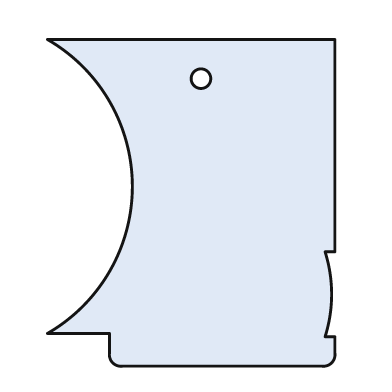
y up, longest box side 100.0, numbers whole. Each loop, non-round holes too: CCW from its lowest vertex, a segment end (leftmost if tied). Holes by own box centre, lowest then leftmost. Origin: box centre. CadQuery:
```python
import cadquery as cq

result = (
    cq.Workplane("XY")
    .moveTo(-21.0, -50.0)
    .lineTo(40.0, -50.0)
    .threePointArc((43.0, -49.0), (44.0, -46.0))
    .lineTo(44.0, -41.0)
    .lineTo(41.0, -41.0)
    .threePointArc((43.0, -28.0), (41.0, -15.0))
    .lineTo(44.0, -15.0)
    .lineTo(44.0, 50.0)
    .lineTo(-44.0, 50.0)
    .threePointArc((-18.0, 5.0), (-44.0, -40.0))
    .lineTo(-25.0, -40.0)
    .lineTo(-25.0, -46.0)
    .threePointArc((-24.0, -49.0), (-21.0, -50.0))
    .close()
    .moveTo(3.0, 38.0)
    .circle(3.0)
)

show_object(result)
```